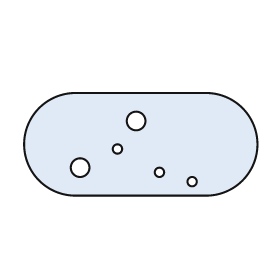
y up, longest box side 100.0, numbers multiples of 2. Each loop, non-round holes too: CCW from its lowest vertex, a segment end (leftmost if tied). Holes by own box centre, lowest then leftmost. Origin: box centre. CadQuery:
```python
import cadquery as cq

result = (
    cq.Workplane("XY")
    .moveTo(-28.0, -22.0)
    .lineTo(28.0, -22.0)
    .threePointArc((50.0, 0.0), (28.0, 22.0))
    .lineTo(-28.0, 22.0)
    .threePointArc((-50.0, 0.0), (-28.0, -22.0))
    .close()
    .moveTo(22.0, -16.0)
    .circle(2.0)
    .moveTo(8.0, -12.0)
    .circle(2.0)
    .moveTo(-26.0, -10.0)
    .circle(4.0)
    .moveTo(-10.0, -2.0)
    .circle(2.0)
    .moveTo(-2.0, 10.0)
    .circle(4.0)
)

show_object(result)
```